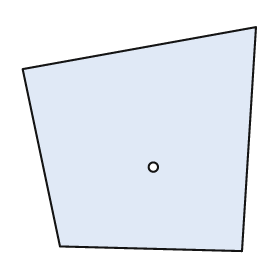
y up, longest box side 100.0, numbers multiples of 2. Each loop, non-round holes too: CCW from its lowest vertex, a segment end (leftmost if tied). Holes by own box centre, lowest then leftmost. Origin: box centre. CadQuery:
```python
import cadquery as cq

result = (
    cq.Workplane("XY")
    .moveTo(44.0, -48.0)
    .lineTo(50.0, 48.0)
    .lineTo(-50.0, 30.0)
    .lineTo(-34.0, -46.0)
    .close()
    .moveTo(6.0, -12.0)
    .circle(2.0)
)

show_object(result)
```